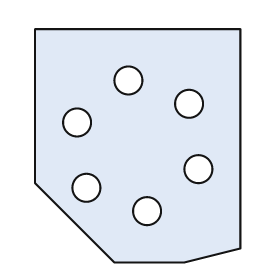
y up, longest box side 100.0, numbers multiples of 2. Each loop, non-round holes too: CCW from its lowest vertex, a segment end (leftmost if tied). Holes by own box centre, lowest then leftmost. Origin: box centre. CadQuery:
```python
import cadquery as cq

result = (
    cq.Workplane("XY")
    .moveTo(-10.0, -50.0)
    .lineTo(20.0, -50.0)
    .lineTo(44.0, -44.0)
    .lineTo(44.0, 50.0)
    .lineTo(-44.0, 50.0)
    .lineTo(-44.0, -16.0)
    .close()
    .moveTo(4.0, -28.0)
    .circle(6.0)
    .moveTo(-22.0, -18.0)
    .circle(6.0)
    .moveTo(26.0, -10.0)
    .circle(6.0)
    .moveTo(-26.0, 10.0)
    .circle(6.0)
    .moveTo(22.0, 18.0)
    .circle(6.0)
    .moveTo(-4.0, 28.0)
    .circle(6.0)
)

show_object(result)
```